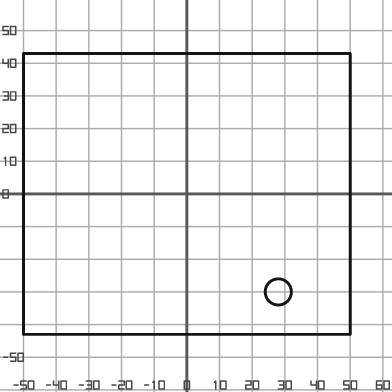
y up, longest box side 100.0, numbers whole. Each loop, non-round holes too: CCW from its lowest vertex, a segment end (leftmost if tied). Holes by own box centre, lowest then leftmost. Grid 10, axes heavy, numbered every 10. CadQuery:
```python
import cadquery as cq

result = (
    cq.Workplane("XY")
    .moveTo(-50.0, -43.0)
    .lineTo(50.0, -43.0)
    .lineTo(50.0, 43.0)
    .lineTo(-50.0, 43.0)
    .close()
    .moveTo(28.0, -30.0)
    .circle(4.0)
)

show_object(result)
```